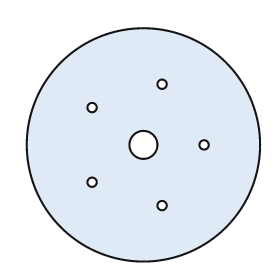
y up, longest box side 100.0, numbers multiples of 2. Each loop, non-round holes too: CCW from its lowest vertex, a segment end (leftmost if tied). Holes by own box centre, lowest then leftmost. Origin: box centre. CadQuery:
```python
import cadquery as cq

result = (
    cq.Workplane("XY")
    .moveTo(0.0, 0.0)
    .circle(50.0)
    .moveTo(8.0, -26.0)
    .circle(2.0)
    .moveTo(-22.0, -16.0)
    .circle(2.0)
    .moveTo(0.0, 0.0)
    .circle(6.0)
    .moveTo(26.0, 0.0)
    .circle(2.0)
    .moveTo(-22.0, 16.0)
    .circle(2.0)
    .moveTo(8.0, 26.0)
    .circle(2.0)
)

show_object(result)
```